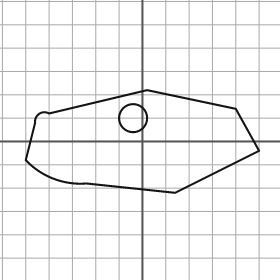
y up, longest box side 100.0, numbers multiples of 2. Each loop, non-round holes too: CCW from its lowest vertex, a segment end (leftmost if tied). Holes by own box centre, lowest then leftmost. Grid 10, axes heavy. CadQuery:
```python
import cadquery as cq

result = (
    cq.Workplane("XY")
    .moveTo(14.0, -22.0)
    .lineTo(50.0, -4.0)
    .lineTo(40.0, 14.0)
    .lineTo(2.0, 22.0)
    .lineTo(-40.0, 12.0)
    .threePointArc((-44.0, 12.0), (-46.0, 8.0))
    .lineTo(-50.0, -8.0)
    .threePointArc((-38.0, -16.0), (-24.0, -18.0))
    .close()
    .moveTo(-4.0, 10.0)
    .circle(6.0)
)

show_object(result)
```